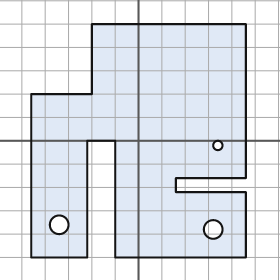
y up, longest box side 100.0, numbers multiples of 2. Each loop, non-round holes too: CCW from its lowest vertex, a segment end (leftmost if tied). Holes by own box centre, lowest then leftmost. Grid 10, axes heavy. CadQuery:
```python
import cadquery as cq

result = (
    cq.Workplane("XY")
    .moveTo(-46.0, -50.0)
    .lineTo(-22.0, -50.0)
    .lineTo(-22.0, 0.0)
    .lineTo(-10.0, 0.0)
    .lineTo(-10.0, -50.0)
    .lineTo(46.0, -50.0)
    .lineTo(46.0, -22.0)
    .lineTo(16.0, -22.0)
    .lineTo(16.0, -16.0)
    .lineTo(46.0, -16.0)
    .lineTo(46.0, 50.0)
    .lineTo(-20.0, 50.0)
    .lineTo(-20.0, 20.0)
    .lineTo(-46.0, 20.0)
    .close()
    .moveTo(32.0, -38.0)
    .circle(4.0)
    .moveTo(-34.0, -36.0)
    .circle(4.0)
    .moveTo(34.0, -2.0)
    .circle(2.0)
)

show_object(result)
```